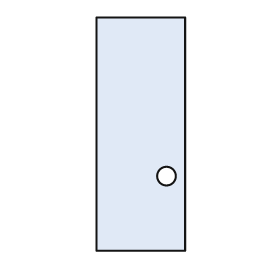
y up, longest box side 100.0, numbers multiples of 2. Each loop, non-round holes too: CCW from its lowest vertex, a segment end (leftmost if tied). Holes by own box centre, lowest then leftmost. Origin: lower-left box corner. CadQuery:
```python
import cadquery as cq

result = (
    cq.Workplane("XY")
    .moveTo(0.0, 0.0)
    .lineTo(38.0, 0.0)
    .lineTo(38.0, 100.0)
    .lineTo(0.0, 100.0)
    .close()
    .moveTo(30.0, 32.0)
    .circle(4.0)
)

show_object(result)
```